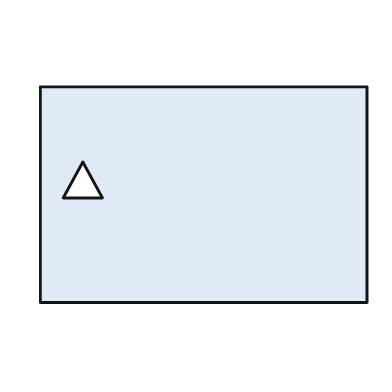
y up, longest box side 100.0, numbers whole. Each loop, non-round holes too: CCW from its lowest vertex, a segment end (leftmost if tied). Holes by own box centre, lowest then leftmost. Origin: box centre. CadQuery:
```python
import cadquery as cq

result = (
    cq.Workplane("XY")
    .moveTo(-50.0, -33.0)
    .lineTo(50.0, -33.0)
    .lineTo(50.0, 33.0)
    .lineTo(-50.0, 33.0)
    .close()
    .moveTo(-43.0, -1.0)
    .lineTo(-31.0, -1.0)
    .lineTo(-37.0, 10.0)
    .close()
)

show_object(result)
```